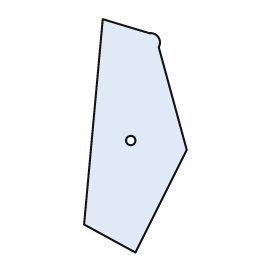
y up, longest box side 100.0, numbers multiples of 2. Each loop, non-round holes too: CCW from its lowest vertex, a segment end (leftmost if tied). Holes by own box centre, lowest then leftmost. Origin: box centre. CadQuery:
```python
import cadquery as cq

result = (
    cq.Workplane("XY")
    .moveTo(0.0, -50.0)
    .lineTo(22.0, -6.0)
    .lineTo(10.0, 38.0)
    .threePointArc((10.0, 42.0), (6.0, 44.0))
    .lineTo(-14.0, 50.0)
    .lineTo(-22.0, -38.0)
    .close()
    .moveTo(-2.0, -2.0)
    .circle(2.0)
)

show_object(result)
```